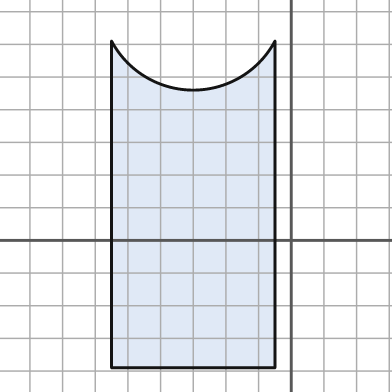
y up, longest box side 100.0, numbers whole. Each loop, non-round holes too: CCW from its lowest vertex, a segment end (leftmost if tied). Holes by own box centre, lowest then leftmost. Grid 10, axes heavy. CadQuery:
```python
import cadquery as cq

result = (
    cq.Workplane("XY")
    .moveTo(-55.0, -39.0)
    .lineTo(-5.0, -39.0)
    .lineTo(-5.0, 61.0)
    .threePointArc((-30.0, 46.0), (-55.0, 61.0))
    .close()
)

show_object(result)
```